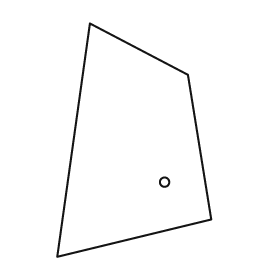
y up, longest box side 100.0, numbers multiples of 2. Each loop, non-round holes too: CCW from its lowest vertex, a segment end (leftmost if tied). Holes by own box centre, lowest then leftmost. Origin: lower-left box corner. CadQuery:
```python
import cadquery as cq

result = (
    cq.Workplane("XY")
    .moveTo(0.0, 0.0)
    .lineTo(66.0, 16.0)
    .lineTo(56.0, 78.0)
    .lineTo(14.0, 100.0)
    .close()
    .moveTo(46.0, 32.0)
    .circle(2.0)
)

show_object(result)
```